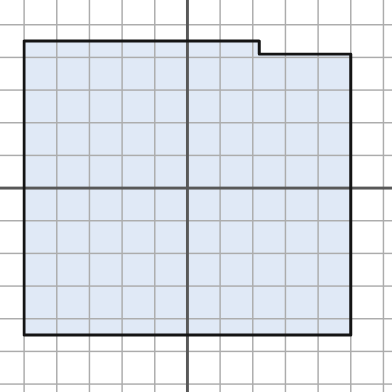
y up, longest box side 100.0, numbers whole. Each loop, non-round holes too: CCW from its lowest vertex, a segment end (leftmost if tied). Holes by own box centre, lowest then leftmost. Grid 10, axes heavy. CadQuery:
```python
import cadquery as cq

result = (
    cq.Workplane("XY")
    .moveTo(-50.0, -45.0)
    .lineTo(50.0, -45.0)
    .lineTo(50.0, 41.0)
    .lineTo(22.0, 41.0)
    .lineTo(22.0, 45.0)
    .lineTo(-50.0, 45.0)
    .close()
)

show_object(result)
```